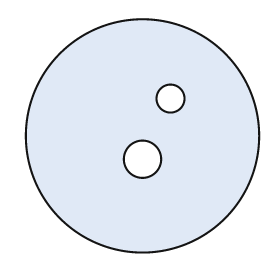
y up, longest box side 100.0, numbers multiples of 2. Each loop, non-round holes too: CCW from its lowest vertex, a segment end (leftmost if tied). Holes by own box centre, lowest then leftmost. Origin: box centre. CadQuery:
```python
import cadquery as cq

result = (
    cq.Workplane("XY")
    .moveTo(0.0, 0.0)
    .circle(50.0)
    .moveTo(0.0, -10.0)
    .circle(8.0)
    .moveTo(12.0, 16.0)
    .circle(6.0)
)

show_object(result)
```